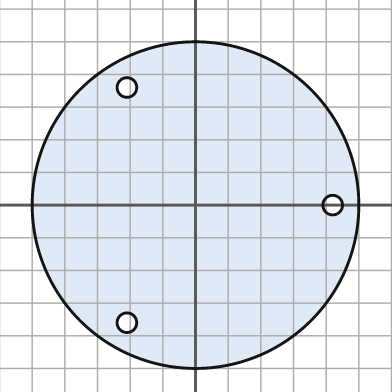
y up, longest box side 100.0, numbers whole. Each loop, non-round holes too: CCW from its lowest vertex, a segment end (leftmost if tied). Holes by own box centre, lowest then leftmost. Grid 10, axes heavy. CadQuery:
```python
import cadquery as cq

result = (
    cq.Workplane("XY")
    .moveTo(0.0, 0.0)
    .circle(50.0)
    .moveTo(-21.0, -36.0)
    .circle(3.0)
    .moveTo(42.0, 0.0)
    .circle(3.0)
    .moveTo(-21.0, 36.0)
    .circle(3.0)
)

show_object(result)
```